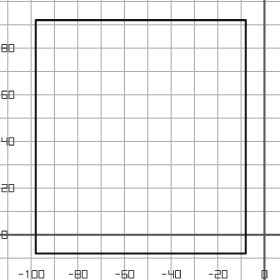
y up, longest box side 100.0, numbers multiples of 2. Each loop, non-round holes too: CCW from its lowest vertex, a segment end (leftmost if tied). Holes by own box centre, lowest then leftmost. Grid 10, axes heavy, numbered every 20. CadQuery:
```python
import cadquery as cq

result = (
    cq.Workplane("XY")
    .moveTo(-98.0, -8.0)
    .lineTo(-8.0, -8.0)
    .lineTo(-8.0, 92.0)
    .lineTo(-98.0, 92.0)
    .close()
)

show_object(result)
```